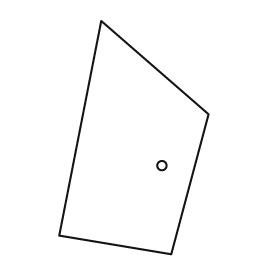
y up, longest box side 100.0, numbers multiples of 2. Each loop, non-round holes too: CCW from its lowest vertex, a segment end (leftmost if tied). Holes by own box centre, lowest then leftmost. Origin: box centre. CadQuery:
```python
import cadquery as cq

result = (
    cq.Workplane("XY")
    .moveTo(16.0, -50.0)
    .lineTo(32.0, 10.0)
    .lineTo(-14.0, 50.0)
    .lineTo(-32.0, -42.0)
    .close()
    .moveTo(12.0, -12.0)
    .circle(2.0)
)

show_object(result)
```